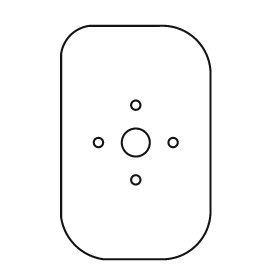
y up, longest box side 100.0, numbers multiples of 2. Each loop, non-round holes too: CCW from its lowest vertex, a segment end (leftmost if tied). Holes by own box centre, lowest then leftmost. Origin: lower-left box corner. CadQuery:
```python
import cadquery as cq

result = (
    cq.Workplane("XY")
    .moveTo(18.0, 0.0)
    .lineTo(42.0, 0.0)
    .threePointArc((58.0, 6.0), (64.0, 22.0))
    .lineTo(64.0, 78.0)
    .threePointArc((58.0, 94.0), (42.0, 100.0))
    .lineTo(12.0, 100.0)
    .threePointArc((4.0, 96.0), (0.0, 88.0))
    .lineTo(0.0, 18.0)
    .threePointArc((6.0, 6.0), (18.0, 0.0))
    .close()
    .moveTo(32.0, 34.0)
    .circle(2.0)
    .moveTo(16.0, 50.0)
    .circle(2.0)
    .moveTo(32.0, 50.0)
    .circle(6.0)
    .moveTo(48.0, 50.0)
    .circle(2.0)
    .moveTo(32.0, 66.0)
    .circle(2.0)
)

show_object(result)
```